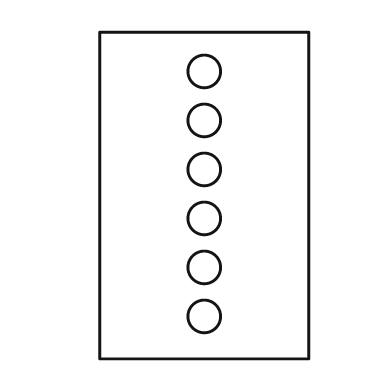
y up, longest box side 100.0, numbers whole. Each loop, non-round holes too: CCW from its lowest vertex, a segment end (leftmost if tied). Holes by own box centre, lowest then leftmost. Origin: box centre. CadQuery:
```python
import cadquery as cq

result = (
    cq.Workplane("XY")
    .moveTo(-32.0, -50.0)
    .lineTo(32.0, -50.0)
    .lineTo(32.0, 50.0)
    .lineTo(-32.0, 50.0)
    .close()
    .moveTo(0.0, -37.0)
    .circle(5.0)
    .moveTo(0.0, -22.0)
    .circle(5.0)
    .moveTo(0.0, -7.0)
    .circle(5.0)
    .moveTo(0.0, 8.0)
    .circle(5.0)
    .moveTo(0.0, 23.0)
    .circle(5.0)
    .moveTo(0.0, 38.0)
    .circle(5.0)
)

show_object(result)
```